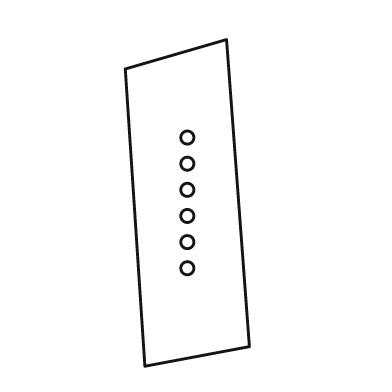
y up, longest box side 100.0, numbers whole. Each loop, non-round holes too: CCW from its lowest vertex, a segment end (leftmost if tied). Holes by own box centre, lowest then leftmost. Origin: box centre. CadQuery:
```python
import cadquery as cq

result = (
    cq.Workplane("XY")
    .moveTo(-13.0, -50.0)
    .lineTo(19.0, -44.0)
    .lineTo(12.0, 50.0)
    .lineTo(-19.0, 41.0)
    .close()
    .moveTo(0.0, -20.0)
    .circle(2.0)
    .moveTo(0.0, -12.0)
    .circle(2.0)
    .moveTo(0.0, -4.0)
    .circle(2.0)
    .moveTo(0.0, 4.0)
    .circle(2.0)
    .moveTo(0.0, 12.0)
    .circle(2.0)
    .moveTo(0.0, 20.0)
    .circle(2.0)
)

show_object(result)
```